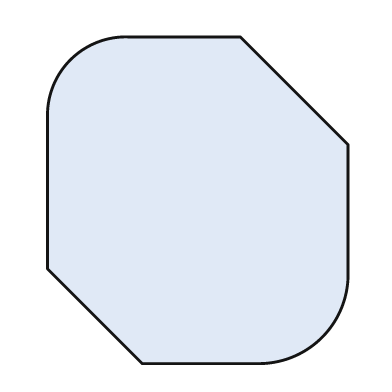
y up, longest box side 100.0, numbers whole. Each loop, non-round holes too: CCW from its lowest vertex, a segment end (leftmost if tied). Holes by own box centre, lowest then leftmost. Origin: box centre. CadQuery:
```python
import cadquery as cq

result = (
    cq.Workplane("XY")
    .moveTo(-17.0, -50.0)
    .lineTo(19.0, -50.0)
    .threePointArc((38.0, -42.0), (46.0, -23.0))
    .lineTo(46.0, 17.0)
    .lineTo(13.0, 50.0)
    .lineTo(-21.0, 50.0)
    .threePointArc((-39.0, 43.0), (-46.0, 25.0))
    .lineTo(-46.0, -21.0)
    .close()
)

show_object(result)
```